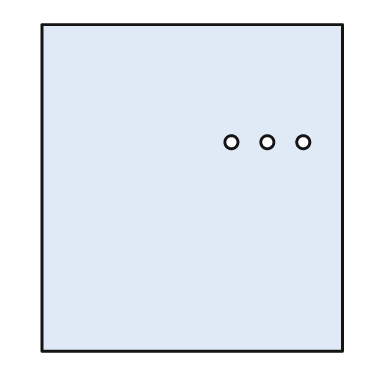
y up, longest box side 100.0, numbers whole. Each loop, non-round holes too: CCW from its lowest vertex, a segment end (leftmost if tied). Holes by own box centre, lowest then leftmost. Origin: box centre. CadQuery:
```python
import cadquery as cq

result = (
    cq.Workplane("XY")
    .moveTo(-46.0, -50.0)
    .lineTo(46.0, -50.0)
    .lineTo(46.0, 50.0)
    .lineTo(-46.0, 50.0)
    .close()
    .moveTo(12.0, 14.0)
    .circle(2.0)
    .moveTo(23.0, 14.0)
    .circle(2.0)
    .moveTo(34.0, 14.0)
    .circle(2.0)
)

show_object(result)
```